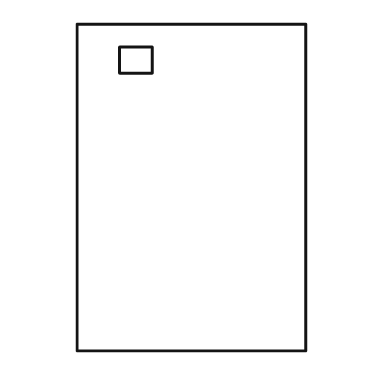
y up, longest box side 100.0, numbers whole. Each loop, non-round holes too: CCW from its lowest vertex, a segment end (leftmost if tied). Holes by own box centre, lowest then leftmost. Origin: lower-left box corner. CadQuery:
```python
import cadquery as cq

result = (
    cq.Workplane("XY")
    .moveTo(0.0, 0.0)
    .lineTo(70.0, 0.0)
    .lineTo(70.0, 100.0)
    .lineTo(0.0, 100.0)
    .close()
    .moveTo(13.0, 85.0)
    .lineTo(23.0, 85.0)
    .lineTo(23.0, 93.0)
    .lineTo(13.0, 93.0)
    .close()
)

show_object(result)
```